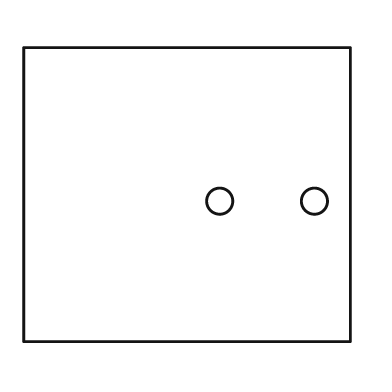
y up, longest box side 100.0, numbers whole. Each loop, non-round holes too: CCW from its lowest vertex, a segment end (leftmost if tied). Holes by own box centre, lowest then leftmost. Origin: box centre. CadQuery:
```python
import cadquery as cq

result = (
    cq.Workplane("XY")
    .moveTo(-50.0, -45.0)
    .lineTo(50.0, -45.0)
    .lineTo(50.0, 45.0)
    .lineTo(-50.0, 45.0)
    .close()
    .moveTo(10.0, -2.0)
    .circle(4.0)
    .moveTo(39.0, -2.0)
    .circle(4.0)
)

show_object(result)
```